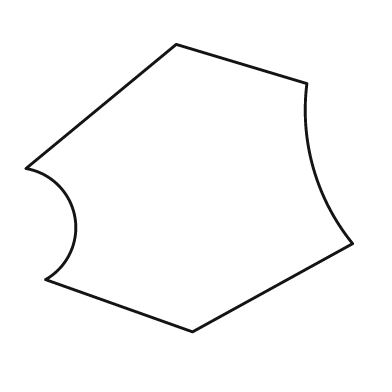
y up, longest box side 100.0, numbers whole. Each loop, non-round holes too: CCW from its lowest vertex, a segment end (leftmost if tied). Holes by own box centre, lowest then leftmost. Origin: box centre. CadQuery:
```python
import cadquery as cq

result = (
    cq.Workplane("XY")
    .moveTo(1.0, -44.0)
    .lineTo(50.0, -17.0)
    .threePointArc((38.0, 6.0), (36.0, 32.0))
    .lineTo(-4.0, 44.0)
    .lineTo(-50.0, 6.0)
    .threePointArc((-35.0, -9.0), (-44.0, -28.0))
    .close()
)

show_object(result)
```